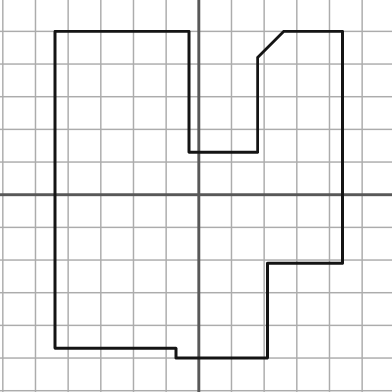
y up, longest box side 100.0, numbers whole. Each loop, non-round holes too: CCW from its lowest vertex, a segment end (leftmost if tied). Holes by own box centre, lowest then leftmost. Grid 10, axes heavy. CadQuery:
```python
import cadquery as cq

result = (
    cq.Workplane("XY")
    .moveTo(-7.0, -50.0)
    .lineTo(21.0, -50.0)
    .lineTo(21.0, -21.0)
    .lineTo(44.0, -21.0)
    .lineTo(44.0, 50.0)
    .lineTo(26.0, 50.0)
    .lineTo(18.0, 42.0)
    .lineTo(18.0, 13.0)
    .lineTo(-3.0, 13.0)
    .lineTo(-3.0, 50.0)
    .lineTo(-44.0, 50.0)
    .lineTo(-44.0, -47.0)
    .lineTo(-7.0, -47.0)
    .close()
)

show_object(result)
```